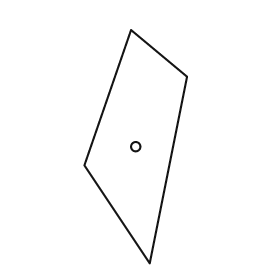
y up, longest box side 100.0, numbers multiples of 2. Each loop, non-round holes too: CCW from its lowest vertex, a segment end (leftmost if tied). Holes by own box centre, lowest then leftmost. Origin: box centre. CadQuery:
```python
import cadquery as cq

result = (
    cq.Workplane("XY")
    .moveTo(6.0, -50.0)
    .lineTo(22.0, 30.0)
    .lineTo(-2.0, 50.0)
    .lineTo(-22.0, -8.0)
    .close()
    .moveTo(0.0, 0.0)
    .circle(2.0)
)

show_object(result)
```